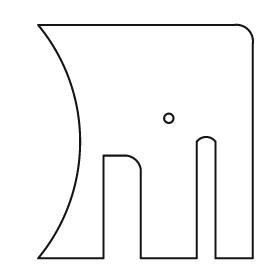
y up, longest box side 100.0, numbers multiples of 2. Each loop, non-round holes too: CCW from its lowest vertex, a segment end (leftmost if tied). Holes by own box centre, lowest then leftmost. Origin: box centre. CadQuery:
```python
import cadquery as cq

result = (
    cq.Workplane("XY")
    .moveTo(-46.0, -50.0)
    .lineTo(-18.0, -50.0)
    .lineTo(-18.0, -6.0)
    .lineTo(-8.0, -6.0)
    .threePointArc((-4.0, -8.0), (-2.0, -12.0))
    .lineTo(-2.0, -50.0)
    .lineTo(22.0, -50.0)
    .lineTo(22.0, 0.0)
    .threePointArc((26.0, 2.0), (30.0, 0.0))
    .lineTo(30.0, -50.0)
    .lineTo(46.0, -50.0)
    .lineTo(46.0, 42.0)
    .threePointArc((44.0, 48.0), (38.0, 50.0))
    .lineTo(-46.0, 50.0)
    .threePointArc((-28.0, 0.0), (-46.0, -50.0))
    .close()
    .moveTo(10.0, 10.0)
    .circle(2.0)
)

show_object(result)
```